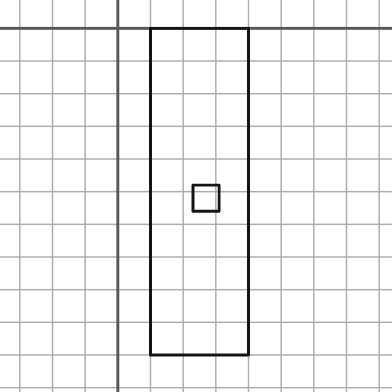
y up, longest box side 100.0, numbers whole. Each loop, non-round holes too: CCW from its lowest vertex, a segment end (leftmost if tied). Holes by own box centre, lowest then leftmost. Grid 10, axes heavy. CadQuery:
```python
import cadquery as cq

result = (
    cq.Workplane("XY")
    .moveTo(10.0, -100.0)
    .lineTo(40.0, -100.0)
    .lineTo(40.0, 0.0)
    .lineTo(10.0, 0.0)
    .close()
    .moveTo(23.0, -56.0)
    .lineTo(31.0, -56.0)
    .lineTo(31.0, -48.0)
    .lineTo(23.0, -48.0)
    .close()
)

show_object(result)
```